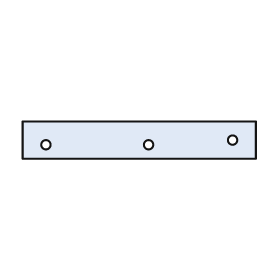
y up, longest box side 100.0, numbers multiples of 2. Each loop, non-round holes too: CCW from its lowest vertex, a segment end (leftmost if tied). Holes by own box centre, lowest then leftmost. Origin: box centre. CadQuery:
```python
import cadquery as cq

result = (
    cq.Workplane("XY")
    .moveTo(-50.0, -8.0)
    .lineTo(50.0, -8.0)
    .lineTo(50.0, 8.0)
    .lineTo(-50.0, 8.0)
    .close()
    .moveTo(-40.0, -2.0)
    .circle(2.0)
    .moveTo(4.0, -2.0)
    .circle(2.0)
    .moveTo(40.0, 0.0)
    .circle(2.0)
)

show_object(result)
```